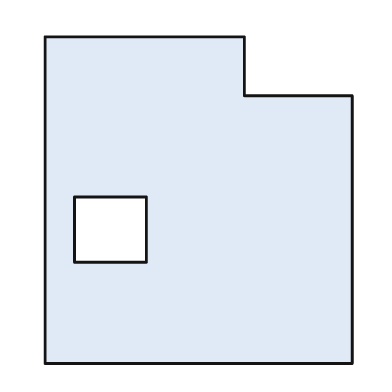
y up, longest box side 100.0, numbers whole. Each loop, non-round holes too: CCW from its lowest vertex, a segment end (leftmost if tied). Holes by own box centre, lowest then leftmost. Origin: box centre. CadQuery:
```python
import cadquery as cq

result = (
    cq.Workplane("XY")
    .moveTo(-47.0, -50.0)
    .lineTo(47.0, -50.0)
    .lineTo(47.0, 32.0)
    .lineTo(14.0, 32.0)
    .lineTo(14.0, 50.0)
    .lineTo(-47.0, 50.0)
    .close()
    .moveTo(-38.0, -19.0)
    .lineTo(-16.0, -19.0)
    .lineTo(-16.0, 1.0)
    .lineTo(-38.0, 1.0)
    .close()
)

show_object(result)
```